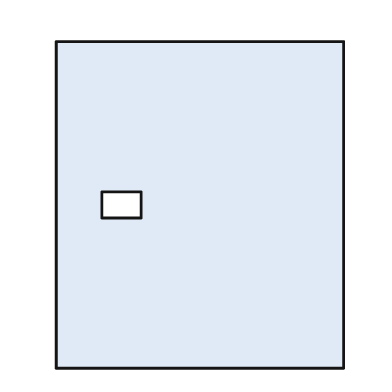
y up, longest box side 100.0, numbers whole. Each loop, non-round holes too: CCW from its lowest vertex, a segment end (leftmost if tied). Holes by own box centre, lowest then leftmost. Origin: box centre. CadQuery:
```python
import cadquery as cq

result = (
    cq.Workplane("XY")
    .moveTo(-44.0, -50.0)
    .lineTo(44.0, -50.0)
    .lineTo(44.0, 50.0)
    .lineTo(-44.0, 50.0)
    .close()
    .moveTo(-30.0, -4.0)
    .lineTo(-18.0, -4.0)
    .lineTo(-18.0, 4.0)
    .lineTo(-30.0, 4.0)
    .close()
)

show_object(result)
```